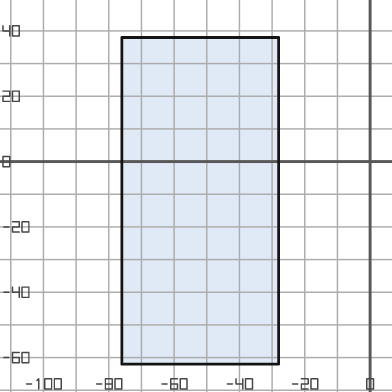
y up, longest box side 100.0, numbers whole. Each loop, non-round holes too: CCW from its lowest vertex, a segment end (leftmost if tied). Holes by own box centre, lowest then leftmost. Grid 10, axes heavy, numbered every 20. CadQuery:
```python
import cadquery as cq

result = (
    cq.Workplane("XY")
    .moveTo(-76.0, -62.0)
    .lineTo(-28.0, -62.0)
    .lineTo(-28.0, 38.0)
    .lineTo(-76.0, 38.0)
    .close()
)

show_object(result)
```